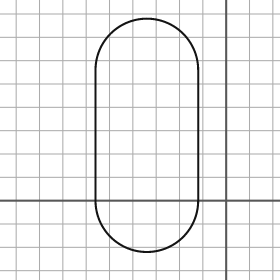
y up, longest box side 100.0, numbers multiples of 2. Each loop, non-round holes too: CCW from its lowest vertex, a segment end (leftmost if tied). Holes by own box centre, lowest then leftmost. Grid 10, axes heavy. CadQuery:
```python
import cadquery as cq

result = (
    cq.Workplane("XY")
    .moveTo(-56.0, 0.0)
    .threePointArc((-34.0, -22.0), (-12.0, 0.0))
    .lineTo(-12.0, 56.0)
    .threePointArc((-34.0, 78.0), (-56.0, 56.0))
    .close()
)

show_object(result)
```